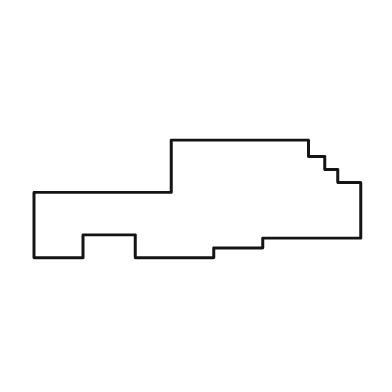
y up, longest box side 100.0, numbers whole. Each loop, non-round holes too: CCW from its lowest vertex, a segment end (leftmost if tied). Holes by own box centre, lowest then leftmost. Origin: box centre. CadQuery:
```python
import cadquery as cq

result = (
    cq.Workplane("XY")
    .moveTo(-50.0, -18.0)
    .lineTo(-35.0, -18.0)
    .lineTo(-35.0, -11.0)
    .lineTo(-19.0, -11.0)
    .lineTo(-19.0, -18.0)
    .lineTo(5.0, -18.0)
    .lineTo(5.0, -15.0)
    .lineTo(20.0, -15.0)
    .lineTo(20.0, -12.0)
    .lineTo(50.0, -12.0)
    .lineTo(50.0, 5.0)
    .lineTo(43.0, 5.0)
    .lineTo(43.0, 9.0)
    .lineTo(39.0, 9.0)
    .lineTo(39.0, 13.0)
    .lineTo(34.0, 13.0)
    .lineTo(34.0, 18.0)
    .lineTo(-8.0, 18.0)
    .lineTo(-8.0, 2.0)
    .lineTo(-50.0, 2.0)
    .close()
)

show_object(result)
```